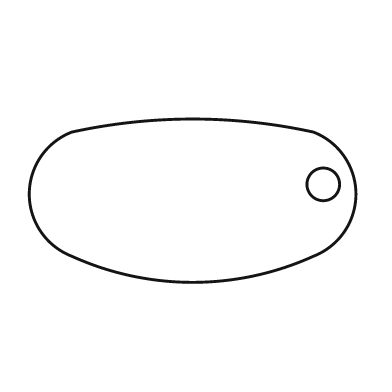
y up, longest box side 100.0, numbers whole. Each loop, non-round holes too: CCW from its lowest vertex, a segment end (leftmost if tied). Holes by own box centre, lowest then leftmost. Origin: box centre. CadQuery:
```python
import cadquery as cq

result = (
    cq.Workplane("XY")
    .moveTo(-37.0, -17.0)
    .threePointArc((0.0, -25.0), (37.0, -17.0))
    .threePointArc((50.0, 2.0), (37.0, 21.0))
    .threePointArc((0.0, 25.0), (-37.0, 21.0))
    .threePointArc((-50.0, 2.0), (-37.0, -17.0))
    .close()
    .moveTo(40.0, 5.0)
    .circle(5.0)
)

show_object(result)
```